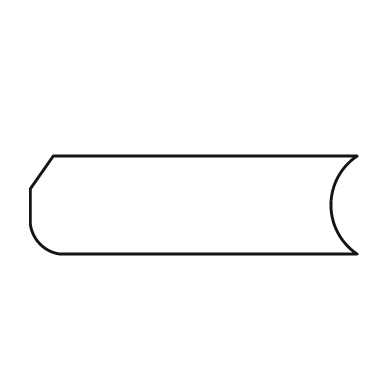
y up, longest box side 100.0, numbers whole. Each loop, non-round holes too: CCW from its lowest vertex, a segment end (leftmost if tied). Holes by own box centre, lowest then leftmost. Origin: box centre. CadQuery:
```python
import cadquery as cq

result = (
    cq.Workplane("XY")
    .moveTo(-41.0, -15.0)
    .lineTo(50.0, -15.0)
    .threePointArc((42.0, 0.0), (50.0, 15.0))
    .lineTo(-43.0, 15.0)
    .lineTo(-50.0, 5.0)
    .lineTo(-50.0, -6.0)
    .threePointArc((-47.0, -12.0), (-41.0, -15.0))
    .close()
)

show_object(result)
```